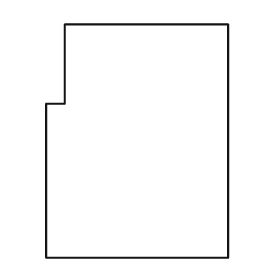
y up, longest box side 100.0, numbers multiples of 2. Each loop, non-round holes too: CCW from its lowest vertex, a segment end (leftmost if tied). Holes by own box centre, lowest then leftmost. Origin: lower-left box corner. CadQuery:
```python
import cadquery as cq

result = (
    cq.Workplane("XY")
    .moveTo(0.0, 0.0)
    .lineTo(78.0, 0.0)
    .lineTo(78.0, 100.0)
    .lineTo(8.0, 100.0)
    .lineTo(8.0, 66.0)
    .lineTo(0.0, 66.0)
    .close()
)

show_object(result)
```